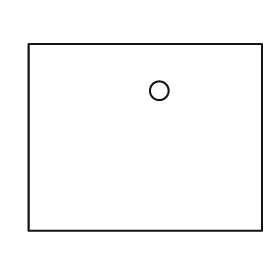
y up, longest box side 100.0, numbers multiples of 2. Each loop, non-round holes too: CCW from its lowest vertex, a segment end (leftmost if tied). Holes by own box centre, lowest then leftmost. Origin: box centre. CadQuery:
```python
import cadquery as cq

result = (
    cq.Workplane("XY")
    .moveTo(-50.0, -40.0)
    .lineTo(50.0, -40.0)
    .lineTo(50.0, 40.0)
    .lineTo(-50.0, 40.0)
    .close()
    .moveTo(6.0, 20.0)
    .circle(4.0)
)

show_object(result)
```